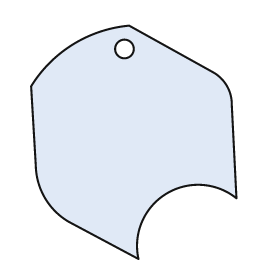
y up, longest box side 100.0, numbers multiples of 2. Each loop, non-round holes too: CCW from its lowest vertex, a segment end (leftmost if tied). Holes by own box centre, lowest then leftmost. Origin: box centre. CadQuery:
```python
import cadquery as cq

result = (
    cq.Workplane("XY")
    .moveTo(2.0, -50.0)
    .threePointArc((14.0, -22.0), (44.0, -24.0))
    .lineTo(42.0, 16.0)
    .threePointArc((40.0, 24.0), (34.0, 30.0))
    .lineTo(-2.0, 50.0)
    .threePointArc((-26.0, 42.0), (-44.0, 24.0))
    .lineTo(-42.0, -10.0)
    .threePointArc((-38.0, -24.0), (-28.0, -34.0))
    .close()
    .moveTo(-4.0, 40.0)
    .circle(4.0)
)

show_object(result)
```